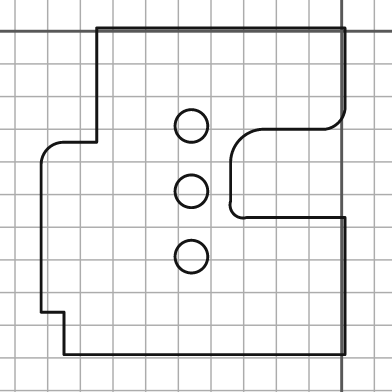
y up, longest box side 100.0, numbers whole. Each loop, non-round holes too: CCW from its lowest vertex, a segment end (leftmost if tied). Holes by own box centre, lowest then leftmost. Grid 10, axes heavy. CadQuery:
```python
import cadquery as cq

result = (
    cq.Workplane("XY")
    .moveTo(-85.0, -99.0)
    .lineTo(1.0, -99.0)
    .lineTo(1.0, -57.0)
    .lineTo(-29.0, -57.0)
    .threePointArc((-33.0, -56.0), (-34.0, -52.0))
    .lineTo(-34.0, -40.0)
    .threePointArc((-31.0, -33.0), (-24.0, -30.0))
    .lineTo(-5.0, -30.0)
    .threePointArc((-1.0, -28.0), (1.0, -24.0))
    .lineTo(1.0, 1.0)
    .lineTo(-75.0, 1.0)
    .lineTo(-75.0, -34.0)
    .lineTo(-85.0, -34.0)
    .threePointArc((-90.0, -36.0), (-92.0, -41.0))
    .lineTo(-92.0, -86.0)
    .lineTo(-85.0, -86.0)
    .close()
    .moveTo(-46.0, -69.0)
    .circle(5.0)
    .moveTo(-46.0, -49.0)
    .circle(5.0)
    .moveTo(-46.0, -29.0)
    .circle(5.0)
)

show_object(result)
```